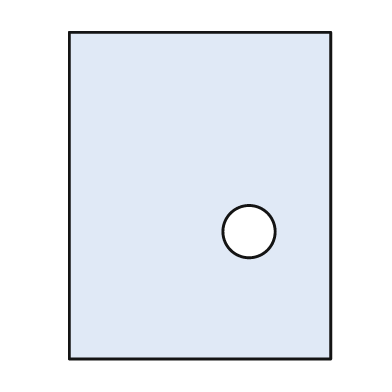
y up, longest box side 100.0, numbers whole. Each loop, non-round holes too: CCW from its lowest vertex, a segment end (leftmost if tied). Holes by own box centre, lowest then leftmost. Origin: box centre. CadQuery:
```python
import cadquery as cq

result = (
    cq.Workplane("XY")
    .moveTo(-40.0, -50.0)
    .lineTo(40.0, -50.0)
    .lineTo(40.0, 50.0)
    .lineTo(-40.0, 50.0)
    .close()
    .moveTo(15.0, -11.0)
    .circle(8.0)
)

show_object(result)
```